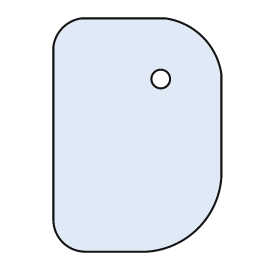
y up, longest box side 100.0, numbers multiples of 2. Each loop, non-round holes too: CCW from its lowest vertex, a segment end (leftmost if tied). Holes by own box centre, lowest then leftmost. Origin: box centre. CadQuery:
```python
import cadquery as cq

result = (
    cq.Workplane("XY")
    .moveTo(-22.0, -50.0)
    .lineTo(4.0, -50.0)
    .threePointArc((26.0, -40.0), (36.0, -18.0))
    .lineTo(36.0, 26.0)
    .threePointArc((28.0, 42.0), (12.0, 50.0))
    .lineTo(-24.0, 50.0)
    .threePointArc((-32.0, 46.0), (-36.0, 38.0))
    .lineTo(-36.0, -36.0)
    .threePointArc((-32.0, -46.0), (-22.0, -50.0))
    .close()
    .moveTo(10.0, 24.0)
    .circle(4.0)
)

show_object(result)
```